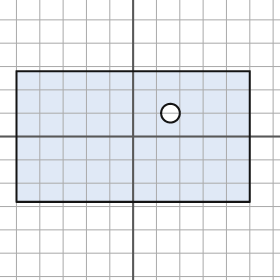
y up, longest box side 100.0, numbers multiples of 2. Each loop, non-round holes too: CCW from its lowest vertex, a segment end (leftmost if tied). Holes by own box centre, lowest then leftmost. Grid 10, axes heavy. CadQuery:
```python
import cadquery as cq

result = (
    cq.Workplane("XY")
    .moveTo(-50.0, -28.0)
    .lineTo(50.0, -28.0)
    .lineTo(50.0, 28.0)
    .lineTo(-50.0, 28.0)
    .close()
    .moveTo(16.0, 10.0)
    .circle(4.0)
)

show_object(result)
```